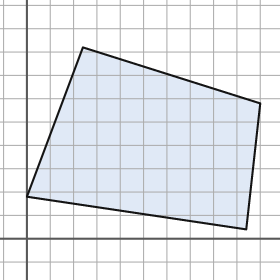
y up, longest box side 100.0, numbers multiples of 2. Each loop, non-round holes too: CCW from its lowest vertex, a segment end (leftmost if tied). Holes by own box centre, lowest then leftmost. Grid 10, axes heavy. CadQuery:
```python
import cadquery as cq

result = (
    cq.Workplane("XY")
    .moveTo(94.0, 4.0)
    .lineTo(100.0, 58.0)
    .lineTo(24.0, 82.0)
    .lineTo(0.0, 18.0)
    .close()
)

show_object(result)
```